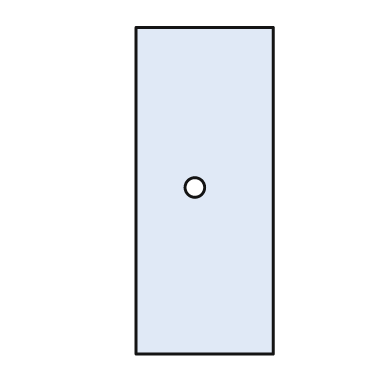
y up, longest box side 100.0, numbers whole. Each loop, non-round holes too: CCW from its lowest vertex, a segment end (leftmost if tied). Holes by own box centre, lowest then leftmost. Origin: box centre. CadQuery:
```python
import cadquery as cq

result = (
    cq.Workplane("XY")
    .moveTo(-21.0, -50.0)
    .lineTo(21.0, -50.0)
    .lineTo(21.0, 50.0)
    .lineTo(-21.0, 50.0)
    .close()
    .moveTo(-3.0, 1.0)
    .circle(3.0)
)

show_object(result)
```